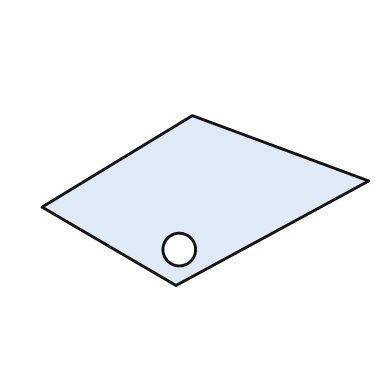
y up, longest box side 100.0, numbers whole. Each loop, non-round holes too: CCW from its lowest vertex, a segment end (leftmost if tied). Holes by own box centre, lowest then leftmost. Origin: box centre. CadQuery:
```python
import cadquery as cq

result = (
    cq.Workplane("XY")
    .moveTo(-9.0, -26.0)
    .lineTo(50.0, 6.0)
    .lineTo(-4.0, 26.0)
    .lineTo(-50.0, -2.0)
    .close()
    .moveTo(-8.0, -15.0)
    .circle(5.0)
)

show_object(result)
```